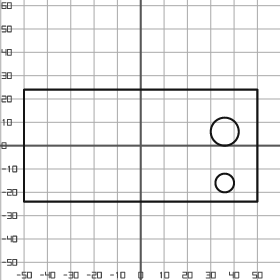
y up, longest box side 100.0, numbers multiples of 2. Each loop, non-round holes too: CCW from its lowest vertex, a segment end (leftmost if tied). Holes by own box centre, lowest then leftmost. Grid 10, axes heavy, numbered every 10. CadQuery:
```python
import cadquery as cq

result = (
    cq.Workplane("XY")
    .moveTo(-50.0, -24.0)
    .lineTo(50.0, -24.0)
    .lineTo(50.0, 24.0)
    .lineTo(-50.0, 24.0)
    .close()
    .moveTo(36.0, -16.0)
    .circle(4.0)
    .moveTo(36.0, 6.0)
    .circle(6.0)
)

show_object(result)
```